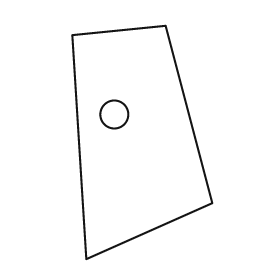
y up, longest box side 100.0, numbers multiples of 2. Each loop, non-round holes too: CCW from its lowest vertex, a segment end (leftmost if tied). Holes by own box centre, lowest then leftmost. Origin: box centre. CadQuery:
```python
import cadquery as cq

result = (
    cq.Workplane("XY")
    .moveTo(-24.0, -50.0)
    .lineTo(30.0, -26.0)
    .lineTo(10.0, 50.0)
    .lineTo(-30.0, 46.0)
    .close()
    .moveTo(-12.0, 12.0)
    .circle(6.0)
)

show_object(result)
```